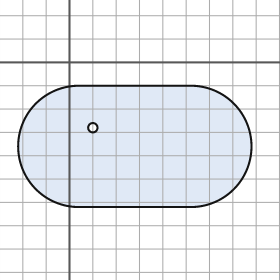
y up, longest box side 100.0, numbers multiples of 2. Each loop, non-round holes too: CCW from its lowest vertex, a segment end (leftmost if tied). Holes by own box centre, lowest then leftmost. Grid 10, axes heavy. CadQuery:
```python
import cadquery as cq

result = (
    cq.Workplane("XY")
    .moveTo(4.0, -62.0)
    .lineTo(52.0, -62.0)
    .threePointArc((78.0, -36.0), (52.0, -10.0))
    .lineTo(4.0, -10.0)
    .threePointArc((-22.0, -36.0), (4.0, -62.0))
    .close()
    .moveTo(10.0, -28.0)
    .circle(2.0)
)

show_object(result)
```